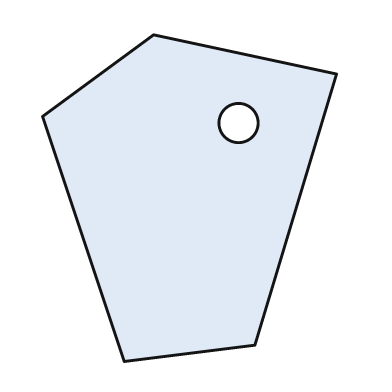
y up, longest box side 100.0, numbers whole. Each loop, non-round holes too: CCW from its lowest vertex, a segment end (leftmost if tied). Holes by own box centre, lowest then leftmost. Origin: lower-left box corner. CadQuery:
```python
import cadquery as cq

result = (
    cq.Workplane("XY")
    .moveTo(25.0, 0.0)
    .lineTo(65.0, 5.0)
    .lineTo(90.0, 88.0)
    .lineTo(34.0, 100.0)
    .lineTo(0.0, 75.0)
    .close()
    .moveTo(60.0, 73.0)
    .circle(6.0)
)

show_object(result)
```